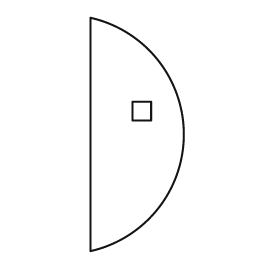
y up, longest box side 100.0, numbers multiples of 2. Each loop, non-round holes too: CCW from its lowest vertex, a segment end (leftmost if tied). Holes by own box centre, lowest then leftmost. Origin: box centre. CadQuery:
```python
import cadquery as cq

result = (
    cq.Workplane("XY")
    .moveTo(-20.0, -50.0)
    .threePointArc((20.0, 0.0), (-20.0, 50.0))
    .close()
    .moveTo(-2.0, 6.0)
    .lineTo(6.0, 6.0)
    .lineTo(6.0, 14.0)
    .lineTo(-2.0, 14.0)
    .close()
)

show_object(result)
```